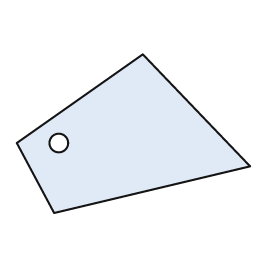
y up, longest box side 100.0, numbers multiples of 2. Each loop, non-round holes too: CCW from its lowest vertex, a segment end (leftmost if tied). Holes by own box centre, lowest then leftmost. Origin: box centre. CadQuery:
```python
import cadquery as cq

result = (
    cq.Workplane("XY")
    .moveTo(-34.0, -34.0)
    .lineTo(50.0, -14.0)
    .lineTo(4.0, 34.0)
    .lineTo(-50.0, -4.0)
    .close()
    .moveTo(-32.0, -4.0)
    .circle(4.0)
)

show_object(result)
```